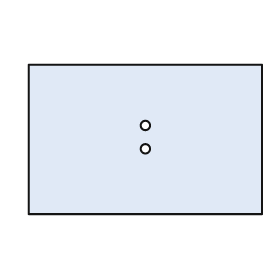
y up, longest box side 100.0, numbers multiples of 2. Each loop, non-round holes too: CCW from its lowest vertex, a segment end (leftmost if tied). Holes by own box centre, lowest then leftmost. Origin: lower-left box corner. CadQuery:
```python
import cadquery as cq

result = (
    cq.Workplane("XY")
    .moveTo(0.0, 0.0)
    .lineTo(100.0, 0.0)
    .lineTo(100.0, 64.0)
    .lineTo(0.0, 64.0)
    .close()
    .moveTo(50.0, 28.0)
    .circle(2.0)
    .moveTo(50.0, 38.0)
    .circle(2.0)
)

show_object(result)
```